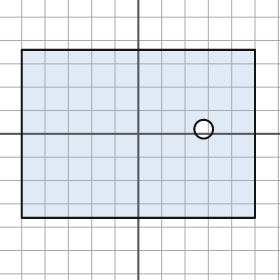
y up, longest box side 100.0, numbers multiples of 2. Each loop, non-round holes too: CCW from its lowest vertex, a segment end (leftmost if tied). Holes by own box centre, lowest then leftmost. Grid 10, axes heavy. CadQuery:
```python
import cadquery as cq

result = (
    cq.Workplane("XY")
    .moveTo(-50.0, -36.0)
    .lineTo(50.0, -36.0)
    .lineTo(50.0, 36.0)
    .lineTo(-50.0, 36.0)
    .close()
    .moveTo(28.0, 2.0)
    .circle(4.0)
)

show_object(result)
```